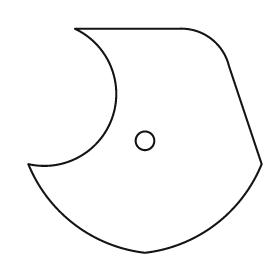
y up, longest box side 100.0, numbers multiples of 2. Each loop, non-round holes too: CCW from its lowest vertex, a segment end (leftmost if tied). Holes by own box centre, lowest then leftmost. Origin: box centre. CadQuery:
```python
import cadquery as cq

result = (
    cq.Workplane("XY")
    .moveTo(0.0, -48.0)
    .threePointArc((30.0, -36.0), (50.0, -10.0))
    .lineTo(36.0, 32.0)
    .threePointArc((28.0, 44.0), (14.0, 48.0))
    .lineTo(-30.0, 48.0)
    .threePointArc((-14.0, 10.0), (-50.0, -10.0))
    .threePointArc((-30.0, -36.0), (0.0, -48.0))
    .close()
    .moveTo(0.0, 0.0)
    .circle(4.0)
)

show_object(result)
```